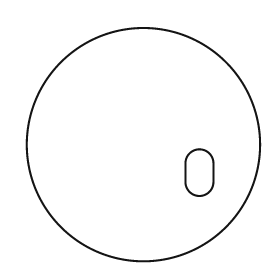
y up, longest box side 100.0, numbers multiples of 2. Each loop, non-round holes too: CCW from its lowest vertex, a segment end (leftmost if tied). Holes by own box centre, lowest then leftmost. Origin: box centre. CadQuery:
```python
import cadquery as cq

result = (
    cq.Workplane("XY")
    .moveTo(0.0, 0.0)
    .circle(50.0)
    .moveTo(18.0, -16.0)
    .threePointArc((24.0, -22.0), (30.0, -16.0))
    .lineTo(30.0, -8.0)
    .threePointArc((24.0, -2.0), (18.0, -8.0))
    .close()
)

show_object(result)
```